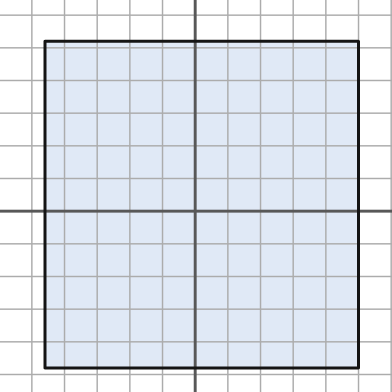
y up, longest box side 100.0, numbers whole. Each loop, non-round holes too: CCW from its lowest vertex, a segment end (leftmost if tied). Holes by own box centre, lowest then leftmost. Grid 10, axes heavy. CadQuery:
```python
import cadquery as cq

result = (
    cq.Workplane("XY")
    .moveTo(-46.0, -48.0)
    .lineTo(50.0, -48.0)
    .lineTo(50.0, 52.0)
    .lineTo(-46.0, 52.0)
    .close()
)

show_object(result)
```